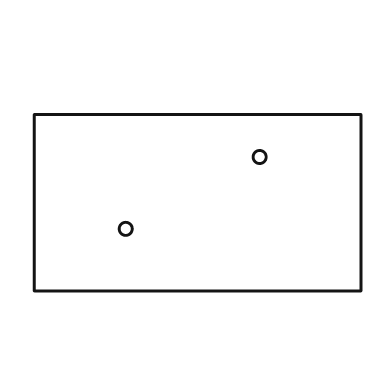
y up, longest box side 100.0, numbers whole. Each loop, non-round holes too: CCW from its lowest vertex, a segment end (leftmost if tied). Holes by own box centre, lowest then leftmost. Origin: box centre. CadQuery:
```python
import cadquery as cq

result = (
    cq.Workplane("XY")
    .moveTo(-50.0, -27.0)
    .lineTo(50.0, -27.0)
    .lineTo(50.0, 27.0)
    .lineTo(-50.0, 27.0)
    .close()
    .moveTo(-22.0, -8.0)
    .circle(2.0)
    .moveTo(19.0, 14.0)
    .circle(2.0)
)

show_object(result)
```